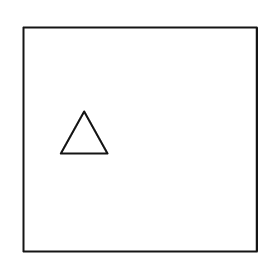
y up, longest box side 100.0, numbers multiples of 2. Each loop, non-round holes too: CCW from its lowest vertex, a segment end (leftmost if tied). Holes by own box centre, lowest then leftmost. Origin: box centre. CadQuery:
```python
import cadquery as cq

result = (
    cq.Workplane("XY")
    .moveTo(-50.0, -48.0)
    .lineTo(50.0, -48.0)
    .lineTo(50.0, 48.0)
    .lineTo(-50.0, 48.0)
    .close()
    .moveTo(-34.0, -6.0)
    .lineTo(-14.0, -6.0)
    .lineTo(-24.0, 12.0)
    .close()
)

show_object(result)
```